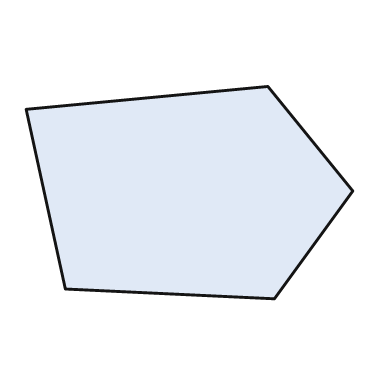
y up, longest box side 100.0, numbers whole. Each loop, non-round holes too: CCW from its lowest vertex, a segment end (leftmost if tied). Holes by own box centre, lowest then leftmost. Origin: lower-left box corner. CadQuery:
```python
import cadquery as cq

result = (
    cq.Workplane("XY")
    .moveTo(76.0, 0.0)
    .lineTo(100.0, 33.0)
    .lineTo(74.0, 65.0)
    .lineTo(0.0, 58.0)
    .lineTo(12.0, 3.0)
    .close()
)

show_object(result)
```